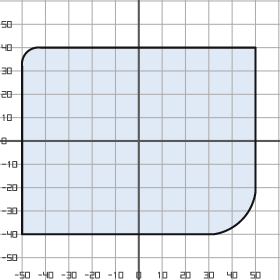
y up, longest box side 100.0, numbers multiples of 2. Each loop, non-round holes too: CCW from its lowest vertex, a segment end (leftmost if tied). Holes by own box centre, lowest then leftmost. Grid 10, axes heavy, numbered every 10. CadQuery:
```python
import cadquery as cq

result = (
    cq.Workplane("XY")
    .moveTo(-50.0, -40.0)
    .lineTo(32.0, -40.0)
    .threePointArc((44.0, -34.0), (50.0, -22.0))
    .lineTo(50.0, 40.0)
    .lineTo(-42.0, 40.0)
    .threePointArc((-48.0, 38.0), (-50.0, 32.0))
    .close()
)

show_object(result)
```